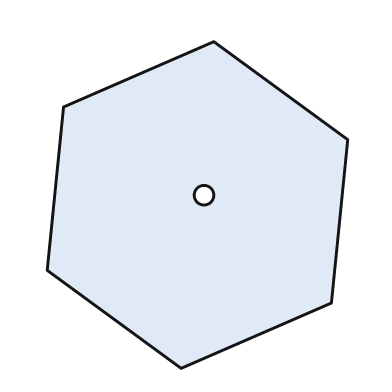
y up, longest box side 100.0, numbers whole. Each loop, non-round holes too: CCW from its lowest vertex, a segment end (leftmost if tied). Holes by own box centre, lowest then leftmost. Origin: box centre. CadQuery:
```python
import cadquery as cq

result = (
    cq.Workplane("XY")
    .moveTo(-5.0, -50.0)
    .lineTo(41.0, -30.0)
    .lineTo(46.0, 20.0)
    .lineTo(5.0, 50.0)
    .lineTo(-41.0, 30.0)
    .lineTo(-46.0, -20.0)
    .close()
    .moveTo(2.0, 3.0)
    .circle(3.0)
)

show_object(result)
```